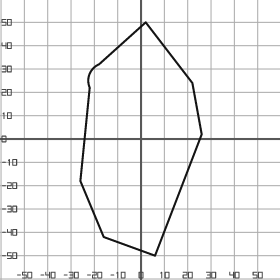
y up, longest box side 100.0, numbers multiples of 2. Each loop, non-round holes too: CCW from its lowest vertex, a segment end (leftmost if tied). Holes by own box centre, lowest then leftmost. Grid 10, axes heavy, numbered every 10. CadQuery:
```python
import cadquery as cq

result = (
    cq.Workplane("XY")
    .moveTo(6.0, -50.0)
    .lineTo(26.0, 2.0)
    .lineTo(22.0, 24.0)
    .lineTo(2.0, 50.0)
    .lineTo(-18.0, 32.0)
    .threePointArc((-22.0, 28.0), (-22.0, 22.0))
    .lineTo(-26.0, -18.0)
    .lineTo(-16.0, -42.0)
    .close()
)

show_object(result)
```